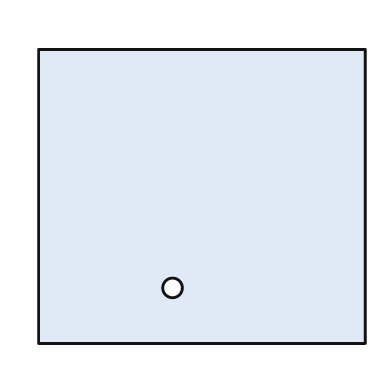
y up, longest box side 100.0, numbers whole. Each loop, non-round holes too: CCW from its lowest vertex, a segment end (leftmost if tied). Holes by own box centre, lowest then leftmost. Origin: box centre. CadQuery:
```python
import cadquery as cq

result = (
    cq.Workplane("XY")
    .moveTo(-50.0, -45.0)
    .lineTo(50.0, -45.0)
    .lineTo(50.0, 45.0)
    .lineTo(-50.0, 45.0)
    .close()
    .moveTo(-9.0, -28.0)
    .circle(3.0)
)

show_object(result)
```